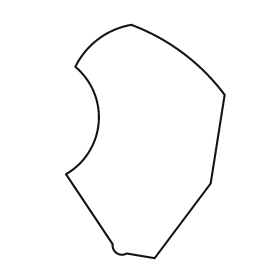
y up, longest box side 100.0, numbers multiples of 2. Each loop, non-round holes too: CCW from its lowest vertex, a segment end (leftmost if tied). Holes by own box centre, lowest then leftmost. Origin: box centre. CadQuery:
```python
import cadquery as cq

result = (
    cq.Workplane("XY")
    .moveTo(4.0, -50.0)
    .lineTo(28.0, -18.0)
    .lineTo(34.0, 20.0)
    .threePointArc((16.0, 38.0), (-6.0, 50.0))
    .threePointArc((-20.0, 44.0), (-30.0, 32.0))
    .threePointArc((-20.0, 8.0), (-34.0, -14.0))
    .lineTo(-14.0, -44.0)
    .threePointArc((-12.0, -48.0), (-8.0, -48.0))
    .close()
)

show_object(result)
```